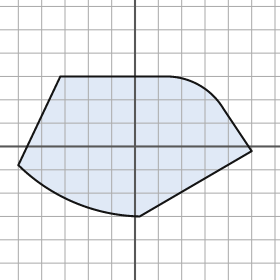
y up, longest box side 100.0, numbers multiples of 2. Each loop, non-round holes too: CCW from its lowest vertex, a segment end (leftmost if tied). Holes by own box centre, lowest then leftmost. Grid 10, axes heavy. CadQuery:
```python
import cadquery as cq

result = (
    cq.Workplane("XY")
    .moveTo(2.0, -30.0)
    .lineTo(50.0, -2.0)
    .lineTo(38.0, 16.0)
    .threePointArc((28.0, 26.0), (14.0, 30.0))
    .lineTo(-32.0, 30.0)
    .lineTo(-50.0, -8.0)
    .threePointArc((-26.0, -24.0), (2.0, -30.0))
    .close()
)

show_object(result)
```